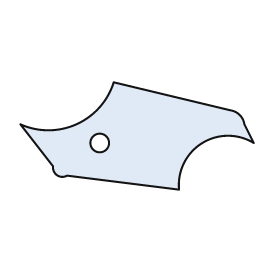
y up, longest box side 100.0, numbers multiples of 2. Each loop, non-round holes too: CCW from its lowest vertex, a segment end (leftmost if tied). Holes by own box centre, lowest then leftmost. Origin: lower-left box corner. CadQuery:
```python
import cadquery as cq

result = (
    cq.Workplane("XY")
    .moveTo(68.0, 0.0)
    .threePointArc((78.0, 20.0), (100.0, 20.0))
    .lineTo(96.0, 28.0)
    .threePointArc((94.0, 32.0), (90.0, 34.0))
    .lineTo(40.0, 46.0)
    .threePointArc((24.0, 28.0), (0.0, 28.0))
    .lineTo(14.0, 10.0)
    .threePointArc((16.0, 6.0), (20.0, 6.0))
    .close()
    .moveTo(34.0, 20.0)
    .circle(4.0)
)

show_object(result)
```